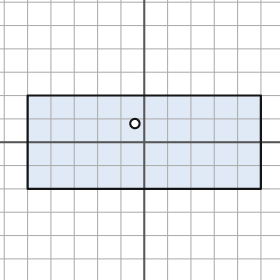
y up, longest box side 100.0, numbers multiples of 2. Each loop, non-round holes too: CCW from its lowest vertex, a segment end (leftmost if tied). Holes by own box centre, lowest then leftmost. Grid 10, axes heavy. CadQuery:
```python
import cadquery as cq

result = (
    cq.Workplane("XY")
    .moveTo(-50.0, -20.0)
    .lineTo(50.0, -20.0)
    .lineTo(50.0, 20.0)
    .lineTo(-50.0, 20.0)
    .close()
    .moveTo(-4.0, 8.0)
    .circle(2.0)
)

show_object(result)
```